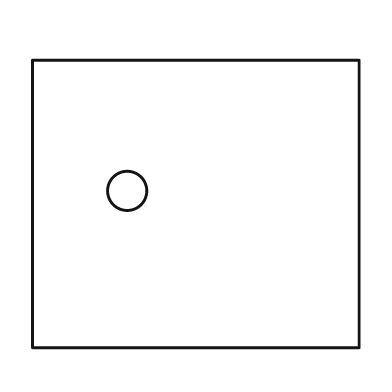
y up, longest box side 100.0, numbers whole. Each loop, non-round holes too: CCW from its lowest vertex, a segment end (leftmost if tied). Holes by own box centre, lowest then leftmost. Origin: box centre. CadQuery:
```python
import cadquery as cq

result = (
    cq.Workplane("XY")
    .moveTo(-50.0, -44.0)
    .lineTo(50.0, -44.0)
    .lineTo(50.0, 44.0)
    .lineTo(-50.0, 44.0)
    .close()
    .moveTo(-21.0, 4.0)
    .circle(6.0)
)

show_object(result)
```